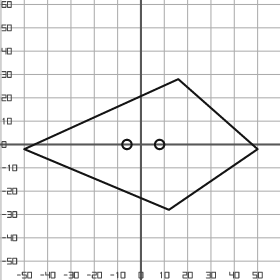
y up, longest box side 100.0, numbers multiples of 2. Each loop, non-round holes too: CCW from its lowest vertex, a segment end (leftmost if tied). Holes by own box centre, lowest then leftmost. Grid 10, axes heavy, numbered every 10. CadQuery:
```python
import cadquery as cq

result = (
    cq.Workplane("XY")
    .moveTo(12.0, -28.0)
    .lineTo(50.0, -2.0)
    .lineTo(16.0, 28.0)
    .lineTo(-50.0, -2.0)
    .close()
    .moveTo(-6.0, 0.0)
    .circle(2.0)
    .moveTo(8.0, 0.0)
    .circle(2.0)
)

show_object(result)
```